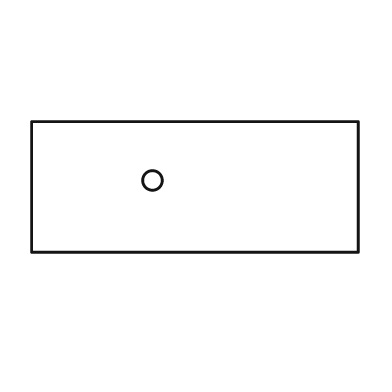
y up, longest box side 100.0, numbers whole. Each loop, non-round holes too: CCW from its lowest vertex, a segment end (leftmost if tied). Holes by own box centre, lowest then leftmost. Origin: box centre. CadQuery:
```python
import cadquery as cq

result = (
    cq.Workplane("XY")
    .moveTo(-50.0, -20.0)
    .lineTo(50.0, -20.0)
    .lineTo(50.0, 20.0)
    .lineTo(-50.0, 20.0)
    .close()
    .moveTo(-13.0, 2.0)
    .circle(3.0)
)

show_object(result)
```